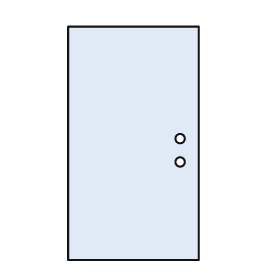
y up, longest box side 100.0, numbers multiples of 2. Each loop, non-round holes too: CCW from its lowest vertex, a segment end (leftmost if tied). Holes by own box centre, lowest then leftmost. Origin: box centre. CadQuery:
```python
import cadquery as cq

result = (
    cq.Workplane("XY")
    .moveTo(-28.0, -50.0)
    .lineTo(28.0, -50.0)
    .lineTo(28.0, 50.0)
    .lineTo(-28.0, 50.0)
    .close()
    .moveTo(20.0, -8.0)
    .circle(2.0)
    .moveTo(20.0, 2.0)
    .circle(2.0)
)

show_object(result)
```